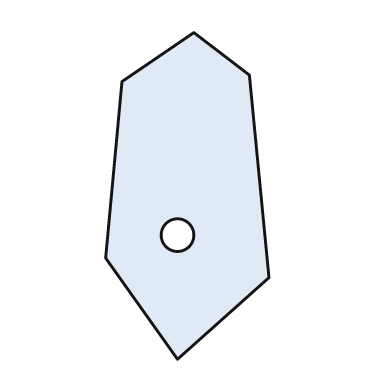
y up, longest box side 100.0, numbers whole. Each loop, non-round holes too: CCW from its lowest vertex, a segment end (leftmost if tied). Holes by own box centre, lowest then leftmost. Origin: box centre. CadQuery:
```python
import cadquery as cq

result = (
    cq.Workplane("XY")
    .moveTo(-3.0, -50.0)
    .lineTo(25.0, -25.0)
    .lineTo(19.0, 37.0)
    .lineTo(2.0, 50.0)
    .lineTo(-20.0, 35.0)
    .lineTo(-25.0, -19.0)
    .close()
    .moveTo(-3.0, -12.0)
    .circle(5.0)
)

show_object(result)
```